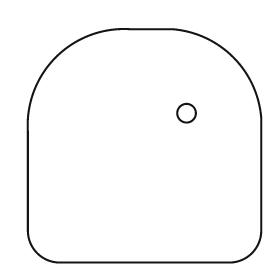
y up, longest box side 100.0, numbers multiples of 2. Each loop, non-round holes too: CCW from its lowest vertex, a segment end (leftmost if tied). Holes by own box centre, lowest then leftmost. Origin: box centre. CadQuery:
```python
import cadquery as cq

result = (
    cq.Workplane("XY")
    .moveTo(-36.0, -50.0)
    .lineTo(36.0, -50.0)
    .threePointArc((46.0, -46.0), (50.0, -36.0))
    .lineTo(50.0, 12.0)
    .threePointArc((38.0, 38.0), (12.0, 50.0))
    .lineTo(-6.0, 50.0)
    .threePointArc((-38.0, 38.0), (-50.0, 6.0))
    .lineTo(-50.0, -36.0)
    .threePointArc((-46.0, -46.0), (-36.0, -50.0))
    .close()
    .moveTo(18.0, 14.0)
    .circle(4.0)
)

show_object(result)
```